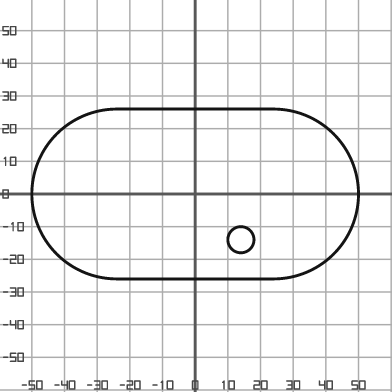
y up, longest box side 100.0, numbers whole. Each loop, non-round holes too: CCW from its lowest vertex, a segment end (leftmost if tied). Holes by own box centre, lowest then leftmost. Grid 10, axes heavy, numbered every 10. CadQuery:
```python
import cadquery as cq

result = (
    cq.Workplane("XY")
    .moveTo(-24.0, -26.0)
    .lineTo(24.0, -26.0)
    .threePointArc((50.0, 0.0), (24.0, 26.0))
    .lineTo(-24.0, 26.0)
    .threePointArc((-50.0, 0.0), (-24.0, -26.0))
    .close()
    .moveTo(14.0, -14.0)
    .circle(4.0)
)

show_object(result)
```